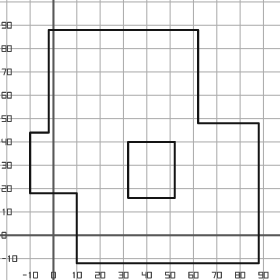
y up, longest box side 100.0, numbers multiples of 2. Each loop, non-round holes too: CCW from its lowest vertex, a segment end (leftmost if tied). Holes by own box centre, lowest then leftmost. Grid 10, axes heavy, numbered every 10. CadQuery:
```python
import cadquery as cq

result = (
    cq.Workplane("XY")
    .moveTo(10.0, -12.0)
    .lineTo(88.0, -12.0)
    .lineTo(88.0, 48.0)
    .lineTo(62.0, 48.0)
    .lineTo(62.0, 88.0)
    .lineTo(-2.0, 88.0)
    .lineTo(-2.0, 44.0)
    .lineTo(-10.0, 44.0)
    .lineTo(-10.0, 18.0)
    .lineTo(10.0, 18.0)
    .close()
    .moveTo(32.0, 16.0)
    .lineTo(52.0, 16.0)
    .lineTo(52.0, 40.0)
    .lineTo(32.0, 40.0)
    .close()
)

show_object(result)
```